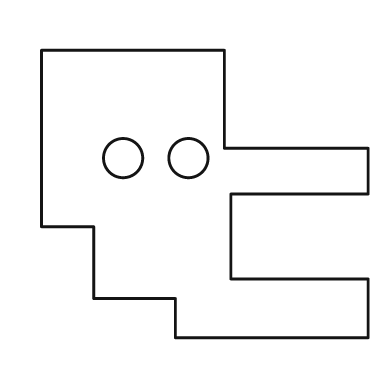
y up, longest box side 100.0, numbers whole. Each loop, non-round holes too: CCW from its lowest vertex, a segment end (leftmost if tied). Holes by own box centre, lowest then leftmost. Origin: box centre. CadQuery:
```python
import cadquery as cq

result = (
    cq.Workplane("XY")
    .moveTo(-9.0, -44.0)
    .lineTo(50.0, -44.0)
    .lineTo(50.0, -26.0)
    .lineTo(8.0, -26.0)
    .lineTo(8.0, 0.0)
    .lineTo(50.0, 0.0)
    .lineTo(50.0, 14.0)
    .lineTo(6.0, 14.0)
    .lineTo(6.0, 44.0)
    .lineTo(-50.0, 44.0)
    .lineTo(-50.0, -10.0)
    .lineTo(-34.0, -10.0)
    .lineTo(-34.0, -32.0)
    .lineTo(-9.0, -32.0)
    .close()
    .moveTo(-25.0, 11.0)
    .circle(6.0)
    .moveTo(-5.0, 11.0)
    .circle(6.0)
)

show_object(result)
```